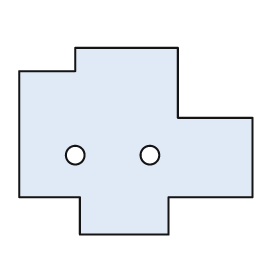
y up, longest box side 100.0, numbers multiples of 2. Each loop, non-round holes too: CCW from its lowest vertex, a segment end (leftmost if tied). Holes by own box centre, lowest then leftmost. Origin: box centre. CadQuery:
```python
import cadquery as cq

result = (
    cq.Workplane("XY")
    .moveTo(-24.0, -40.0)
    .lineTo(14.0, -40.0)
    .lineTo(14.0, -24.0)
    .lineTo(50.0, -24.0)
    .lineTo(50.0, 10.0)
    .lineTo(18.0, 10.0)
    .lineTo(18.0, 40.0)
    .lineTo(-26.0, 40.0)
    .lineTo(-26.0, 30.0)
    .lineTo(-50.0, 30.0)
    .lineTo(-50.0, -24.0)
    .lineTo(-24.0, -24.0)
    .close()
    .moveTo(-26.0, -6.0)
    .circle(4.0)
    .moveTo(6.0, -6.0)
    .circle(4.0)
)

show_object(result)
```